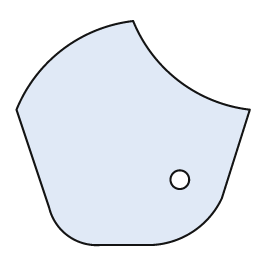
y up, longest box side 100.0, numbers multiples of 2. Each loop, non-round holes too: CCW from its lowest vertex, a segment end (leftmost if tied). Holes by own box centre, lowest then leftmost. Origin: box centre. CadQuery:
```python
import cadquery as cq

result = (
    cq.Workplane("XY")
    .moveTo(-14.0, -48.0)
    .lineTo(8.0, -48.0)
    .threePointArc((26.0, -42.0), (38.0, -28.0))
    .lineTo(50.0, 10.0)
    .threePointArc((20.0, 22.0), (0.0, 48.0))
    .threePointArc((-30.0, 36.0), (-50.0, 10.0))
    .lineTo(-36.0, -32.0)
    .threePointArc((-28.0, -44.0), (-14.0, -48.0))
    .close()
    .moveTo(20.0, -20.0)
    .circle(4.0)
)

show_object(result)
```